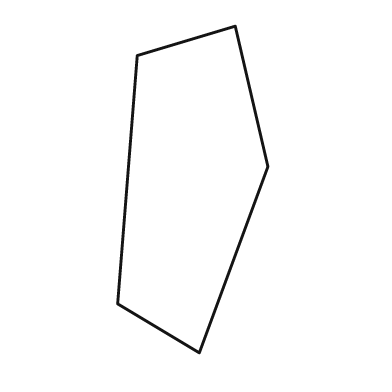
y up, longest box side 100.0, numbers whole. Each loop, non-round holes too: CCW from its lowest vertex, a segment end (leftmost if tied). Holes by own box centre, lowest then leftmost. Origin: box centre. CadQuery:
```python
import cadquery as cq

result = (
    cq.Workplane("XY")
    .moveTo(2.0, -50.0)
    .lineTo(23.0, 7.0)
    .lineTo(13.0, 50.0)
    .lineTo(-17.0, 41.0)
    .lineTo(-23.0, -35.0)
    .close()
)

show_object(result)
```